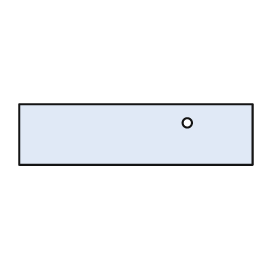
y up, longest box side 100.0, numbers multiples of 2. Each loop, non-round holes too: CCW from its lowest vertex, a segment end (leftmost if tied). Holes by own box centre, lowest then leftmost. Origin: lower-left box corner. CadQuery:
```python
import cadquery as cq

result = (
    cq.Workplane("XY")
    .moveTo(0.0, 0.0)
    .lineTo(100.0, 0.0)
    .lineTo(100.0, 26.0)
    .lineTo(0.0, 26.0)
    .close()
    .moveTo(72.0, 18.0)
    .circle(2.0)
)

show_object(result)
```